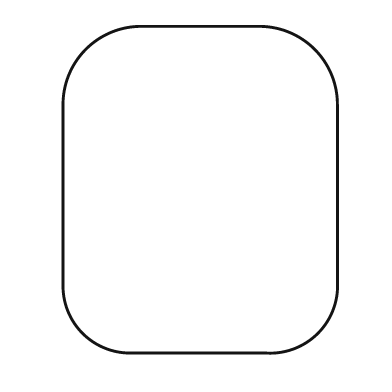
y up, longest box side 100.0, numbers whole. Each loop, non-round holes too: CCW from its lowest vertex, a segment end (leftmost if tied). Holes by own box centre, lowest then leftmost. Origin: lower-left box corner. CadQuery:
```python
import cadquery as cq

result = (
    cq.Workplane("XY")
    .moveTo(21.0, 0.0)
    .lineTo(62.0, 0.0)
    .threePointArc((78.0, 6.0), (84.0, 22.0))
    .lineTo(84.0, 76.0)
    .threePointArc((77.0, 93.0), (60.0, 100.0))
    .lineTo(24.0, 100.0)
    .threePointArc((7.0, 93.0), (0.0, 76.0))
    .lineTo(0.0, 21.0)
    .threePointArc((6.0, 6.0), (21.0, 0.0))
    .close()
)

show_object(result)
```